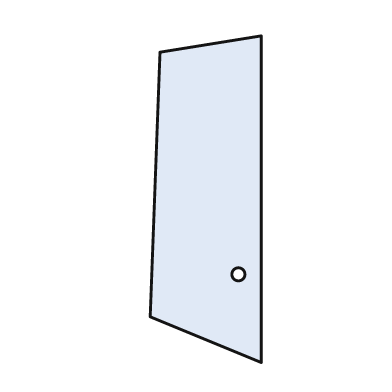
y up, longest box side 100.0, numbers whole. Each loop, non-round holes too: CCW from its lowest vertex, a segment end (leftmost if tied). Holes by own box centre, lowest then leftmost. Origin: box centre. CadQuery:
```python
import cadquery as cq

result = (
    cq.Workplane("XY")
    .moveTo(17.0, -50.0)
    .lineTo(17.0, 50.0)
    .lineTo(-14.0, 45.0)
    .lineTo(-17.0, -36.0)
    .close()
    .moveTo(10.0, -23.0)
    .circle(2.0)
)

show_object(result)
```